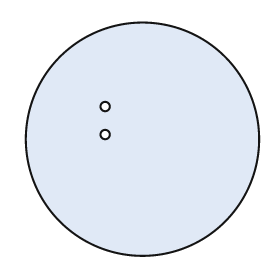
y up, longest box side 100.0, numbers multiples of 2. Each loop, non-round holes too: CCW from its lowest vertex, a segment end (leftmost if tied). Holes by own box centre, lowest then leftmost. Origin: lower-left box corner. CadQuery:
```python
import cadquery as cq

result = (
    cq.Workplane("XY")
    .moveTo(50.0, 50.0)
    .circle(50.0)
    .moveTo(34.0, 52.0)
    .circle(2.0)
    .moveTo(34.0, 64.0)
    .circle(2.0)
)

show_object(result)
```